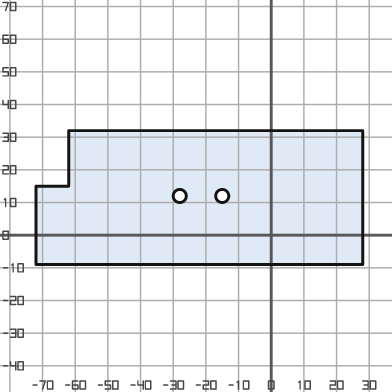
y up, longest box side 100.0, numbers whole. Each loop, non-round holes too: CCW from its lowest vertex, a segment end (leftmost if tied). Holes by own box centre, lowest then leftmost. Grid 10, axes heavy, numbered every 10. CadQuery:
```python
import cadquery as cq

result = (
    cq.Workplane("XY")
    .moveTo(-72.0, -9.0)
    .lineTo(28.0, -9.0)
    .lineTo(28.0, 32.0)
    .lineTo(-62.0, 32.0)
    .lineTo(-62.0, 15.0)
    .lineTo(-72.0, 15.0)
    .close()
    .moveTo(-28.0, 12.0)
    .circle(2.0)
    .moveTo(-15.0, 12.0)
    .circle(2.0)
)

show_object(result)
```